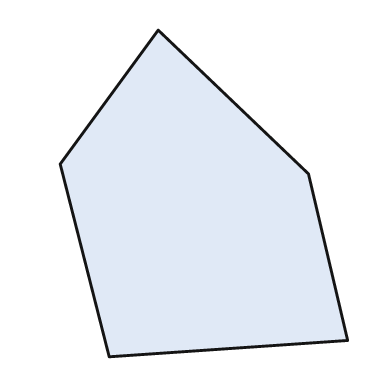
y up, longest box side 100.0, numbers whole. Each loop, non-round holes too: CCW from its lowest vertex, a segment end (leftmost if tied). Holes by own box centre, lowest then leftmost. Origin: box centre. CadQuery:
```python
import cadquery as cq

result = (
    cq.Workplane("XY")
    .moveTo(-29.0, -50.0)
    .lineTo(44.0, -45.0)
    .lineTo(32.0, 6.0)
    .lineTo(-14.0, 50.0)
    .lineTo(-44.0, 9.0)
    .close()
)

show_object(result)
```